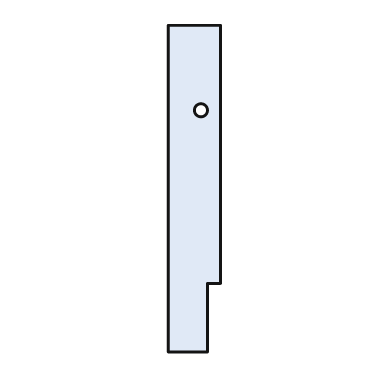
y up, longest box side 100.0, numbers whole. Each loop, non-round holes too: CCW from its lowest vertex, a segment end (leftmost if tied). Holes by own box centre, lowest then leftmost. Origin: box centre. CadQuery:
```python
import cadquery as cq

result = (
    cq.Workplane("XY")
    .moveTo(-8.0, -50.0)
    .lineTo(4.0, -50.0)
    .lineTo(4.0, -29.0)
    .lineTo(8.0, -29.0)
    .lineTo(8.0, 50.0)
    .lineTo(-8.0, 50.0)
    .close()
    .moveTo(2.0, 24.0)
    .circle(2.0)
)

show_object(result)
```